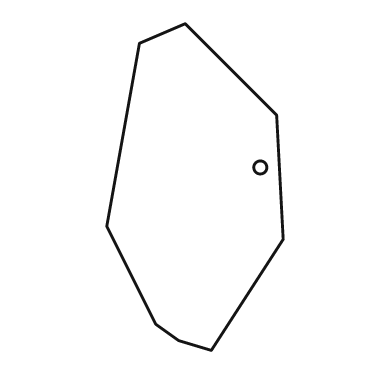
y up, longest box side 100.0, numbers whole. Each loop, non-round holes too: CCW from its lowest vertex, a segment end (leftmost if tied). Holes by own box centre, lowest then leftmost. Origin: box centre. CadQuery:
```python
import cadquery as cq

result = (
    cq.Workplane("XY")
    .moveTo(5.0, -50.0)
    .lineTo(27.0, -16.0)
    .lineTo(25.0, 22.0)
    .lineTo(-3.0, 50.0)
    .lineTo(-17.0, 44.0)
    .lineTo(-27.0, -12.0)
    .lineTo(-12.0, -42.0)
    .lineTo(-5.0, -47.0)
    .close()
    .moveTo(20.0, 6.0)
    .circle(2.0)
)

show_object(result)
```